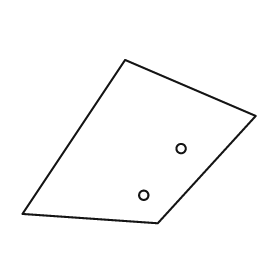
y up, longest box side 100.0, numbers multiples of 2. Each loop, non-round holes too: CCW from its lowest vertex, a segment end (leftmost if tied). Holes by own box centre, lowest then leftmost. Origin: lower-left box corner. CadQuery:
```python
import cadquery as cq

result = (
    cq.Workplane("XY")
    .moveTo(58.0, 0.0)
    .lineTo(100.0, 46.0)
    .lineTo(44.0, 70.0)
    .lineTo(0.0, 4.0)
    .close()
    .moveTo(52.0, 12.0)
    .circle(2.0)
    .moveTo(68.0, 32.0)
    .circle(2.0)
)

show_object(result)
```